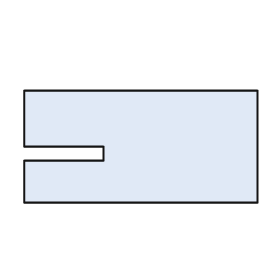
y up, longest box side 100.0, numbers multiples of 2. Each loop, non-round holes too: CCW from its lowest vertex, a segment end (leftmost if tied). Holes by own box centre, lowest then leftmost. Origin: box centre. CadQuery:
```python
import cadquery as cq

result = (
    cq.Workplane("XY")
    .moveTo(-50.0, -24.0)
    .lineTo(50.0, -24.0)
    .lineTo(50.0, 24.0)
    .lineTo(-50.0, 24.0)
    .lineTo(-50.0, 0.0)
    .lineTo(-16.0, 0.0)
    .lineTo(-16.0, -6.0)
    .lineTo(-50.0, -6.0)
    .close()
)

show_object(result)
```